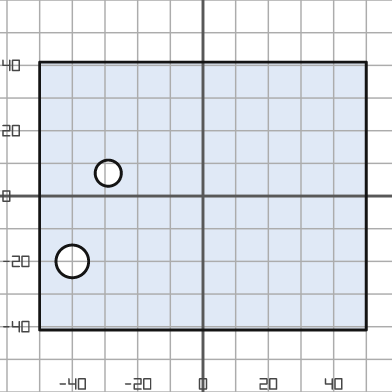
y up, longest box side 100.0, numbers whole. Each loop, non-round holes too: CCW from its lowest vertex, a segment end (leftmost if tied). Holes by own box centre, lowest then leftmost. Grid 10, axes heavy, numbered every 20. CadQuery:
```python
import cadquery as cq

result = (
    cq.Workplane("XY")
    .moveTo(-50.0, -41.0)
    .lineTo(50.0, -41.0)
    .lineTo(50.0, 41.0)
    .lineTo(-50.0, 41.0)
    .close()
    .moveTo(-40.0, -20.0)
    .circle(5.0)
    .moveTo(-29.0, 7.0)
    .circle(4.0)
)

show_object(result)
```